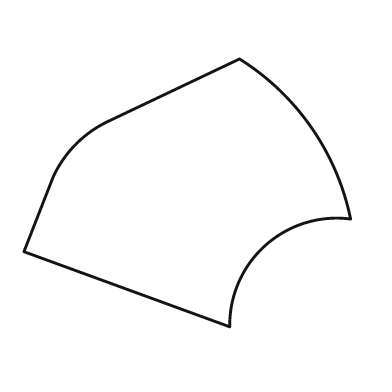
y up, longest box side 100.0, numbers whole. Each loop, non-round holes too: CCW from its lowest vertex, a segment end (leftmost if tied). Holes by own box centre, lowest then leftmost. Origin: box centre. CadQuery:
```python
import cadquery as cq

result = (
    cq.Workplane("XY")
    .moveTo(13.0, -41.0)
    .threePointArc((24.0, -16.0), (50.0, -8.0))
    .threePointArc((38.0, 20.0), (16.0, 41.0))
    .lineTo(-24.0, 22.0)
    .threePointArc((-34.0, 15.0), (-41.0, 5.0))
    .lineTo(-50.0, -18.0)
    .close()
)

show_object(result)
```